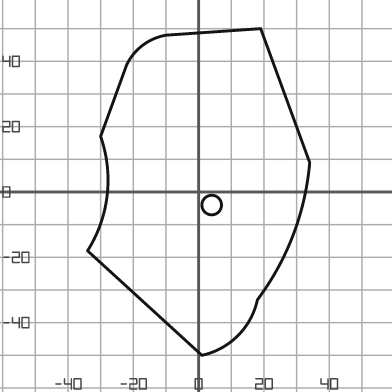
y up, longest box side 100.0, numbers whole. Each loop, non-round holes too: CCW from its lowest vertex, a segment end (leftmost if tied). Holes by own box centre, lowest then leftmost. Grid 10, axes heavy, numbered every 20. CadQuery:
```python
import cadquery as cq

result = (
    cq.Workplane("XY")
    .moveTo(1.0, -50.0)
    .threePointArc((12.0, -44.0), (18.0, -33.0))
    .threePointArc((29.0, -13.0), (34.0, 9.0))
    .lineTo(19.0, 50.0)
    .lineTo(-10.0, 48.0)
    .threePointArc((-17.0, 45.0), (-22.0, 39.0))
    .lineTo(-30.0, 17.0)
    .threePointArc((-28.0, -1.0), (-34.0, -18.0))
    .close()
    .moveTo(4.0, -4.0)
    .circle(3.0)
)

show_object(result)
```